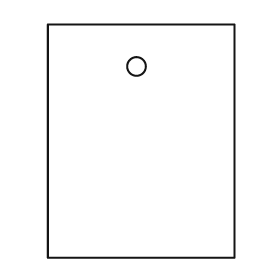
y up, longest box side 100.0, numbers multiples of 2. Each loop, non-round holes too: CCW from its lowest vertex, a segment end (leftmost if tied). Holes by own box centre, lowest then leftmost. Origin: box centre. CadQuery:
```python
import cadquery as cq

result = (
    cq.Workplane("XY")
    .moveTo(-40.0, -50.0)
    .lineTo(40.0, -50.0)
    .lineTo(40.0, 50.0)
    .lineTo(-40.0, 50.0)
    .close()
    .moveTo(-2.0, 32.0)
    .circle(4.0)
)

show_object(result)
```